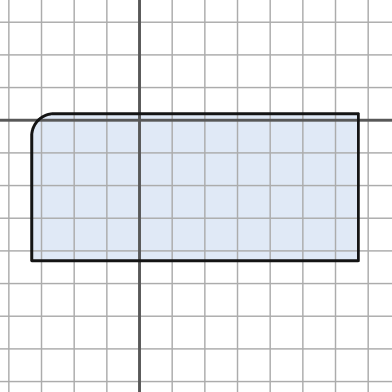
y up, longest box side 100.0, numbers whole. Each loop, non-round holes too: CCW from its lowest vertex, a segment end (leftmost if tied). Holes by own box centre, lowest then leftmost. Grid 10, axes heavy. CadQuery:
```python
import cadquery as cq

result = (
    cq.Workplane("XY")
    .moveTo(-33.0, -43.0)
    .lineTo(67.0, -43.0)
    .lineTo(67.0, 2.0)
    .lineTo(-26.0, 2.0)
    .threePointArc((-31.0, 0.0), (-33.0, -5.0))
    .close()
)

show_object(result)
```